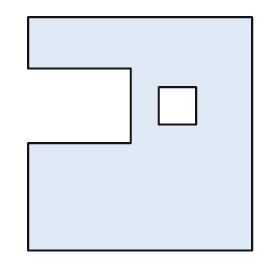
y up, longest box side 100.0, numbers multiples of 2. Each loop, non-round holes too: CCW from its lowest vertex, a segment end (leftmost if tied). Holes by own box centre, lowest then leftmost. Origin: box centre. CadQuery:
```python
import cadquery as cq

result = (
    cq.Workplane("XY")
    .moveTo(-48.0, -50.0)
    .lineTo(48.0, -50.0)
    .lineTo(48.0, 50.0)
    .lineTo(-48.0, 50.0)
    .lineTo(-48.0, 28.0)
    .lineTo(-4.0, 28.0)
    .lineTo(-4.0, -4.0)
    .lineTo(-48.0, -4.0)
    .close()
    .moveTo(8.0, 4.0)
    .lineTo(24.0, 4.0)
    .lineTo(24.0, 20.0)
    .lineTo(8.0, 20.0)
    .close()
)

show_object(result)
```